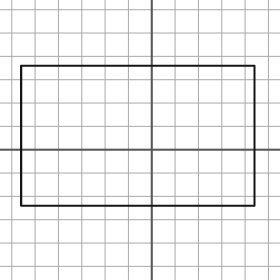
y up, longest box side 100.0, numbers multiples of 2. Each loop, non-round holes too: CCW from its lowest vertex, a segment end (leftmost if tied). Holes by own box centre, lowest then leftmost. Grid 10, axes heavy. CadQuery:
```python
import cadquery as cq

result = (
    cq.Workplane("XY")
    .moveTo(-56.0, -24.0)
    .lineTo(44.0, -24.0)
    .lineTo(44.0, 36.0)
    .lineTo(-56.0, 36.0)
    .close()
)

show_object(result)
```